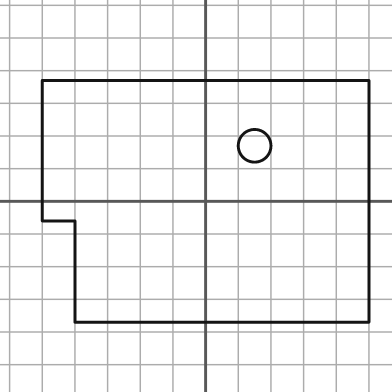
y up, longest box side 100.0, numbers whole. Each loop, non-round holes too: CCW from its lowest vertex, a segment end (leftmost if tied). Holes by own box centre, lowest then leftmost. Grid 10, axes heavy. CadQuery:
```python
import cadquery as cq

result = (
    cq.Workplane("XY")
    .moveTo(-40.0, -37.0)
    .lineTo(50.0, -37.0)
    .lineTo(50.0, 37.0)
    .lineTo(-50.0, 37.0)
    .lineTo(-50.0, -6.0)
    .lineTo(-40.0, -6.0)
    .close()
    .moveTo(15.0, 17.0)
    .circle(5.0)
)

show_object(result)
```